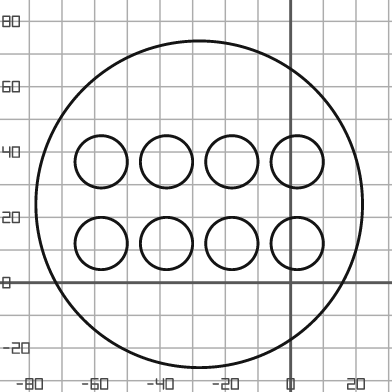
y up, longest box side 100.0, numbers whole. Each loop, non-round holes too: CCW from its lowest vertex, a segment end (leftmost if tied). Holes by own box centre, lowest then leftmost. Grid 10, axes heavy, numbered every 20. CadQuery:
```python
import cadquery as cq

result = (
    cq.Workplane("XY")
    .moveTo(-28.0, 24.0)
    .circle(50.0)
    .moveTo(-58.0, 12.0)
    .circle(8.0)
    .moveTo(-38.0, 12.0)
    .circle(8.0)
    .moveTo(-18.0, 12.0)
    .circle(8.0)
    .moveTo(2.0, 12.0)
    .circle(8.0)
    .moveTo(-58.0, 37.0)
    .circle(8.0)
    .moveTo(-38.0, 37.0)
    .circle(8.0)
    .moveTo(-18.0, 37.0)
    .circle(8.0)
    .moveTo(2.0, 37.0)
    .circle(8.0)
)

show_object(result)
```